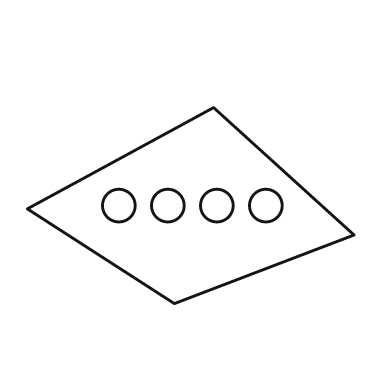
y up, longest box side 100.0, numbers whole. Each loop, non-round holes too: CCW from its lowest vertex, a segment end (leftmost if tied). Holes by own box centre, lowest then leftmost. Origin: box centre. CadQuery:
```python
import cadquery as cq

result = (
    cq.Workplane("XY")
    .moveTo(-5.0, -30.0)
    .lineTo(50.0, -9.0)
    .lineTo(7.0, 30.0)
    .lineTo(-50.0, -1.0)
    .close()
    .moveTo(-22.0, 0.0)
    .circle(5.0)
    .moveTo(-7.0, 0.0)
    .circle(5.0)
    .moveTo(8.0, 0.0)
    .circle(5.0)
    .moveTo(23.0, 0.0)
    .circle(5.0)
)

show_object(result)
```